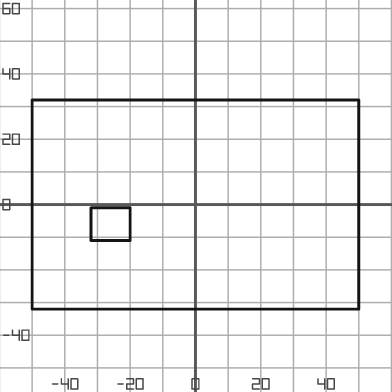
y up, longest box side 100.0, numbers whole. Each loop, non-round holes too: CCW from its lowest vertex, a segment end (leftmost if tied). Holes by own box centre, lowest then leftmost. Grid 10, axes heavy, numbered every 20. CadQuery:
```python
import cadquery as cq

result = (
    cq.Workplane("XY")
    .moveTo(-50.0, -32.0)
    .lineTo(50.0, -32.0)
    .lineTo(50.0, 32.0)
    .lineTo(-50.0, 32.0)
    .close()
    .moveTo(-32.0, -11.0)
    .lineTo(-20.0, -11.0)
    .lineTo(-20.0, -1.0)
    .lineTo(-32.0, -1.0)
    .close()
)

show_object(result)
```